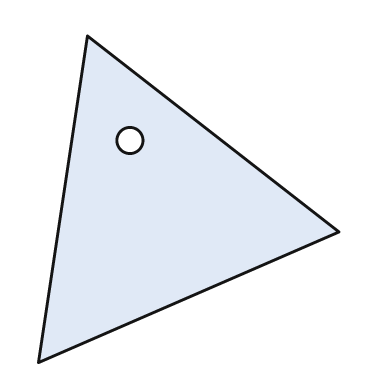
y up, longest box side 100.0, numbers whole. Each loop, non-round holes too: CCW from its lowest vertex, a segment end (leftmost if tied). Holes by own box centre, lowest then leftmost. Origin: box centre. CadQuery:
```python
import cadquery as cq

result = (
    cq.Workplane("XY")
    .moveTo(-46.0, -50.0)
    .lineTo(46.0, -10.0)
    .lineTo(-31.0, 50.0)
    .close()
    .moveTo(-18.0, 18.0)
    .circle(4.0)
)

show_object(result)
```